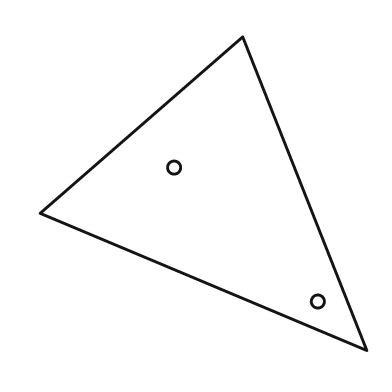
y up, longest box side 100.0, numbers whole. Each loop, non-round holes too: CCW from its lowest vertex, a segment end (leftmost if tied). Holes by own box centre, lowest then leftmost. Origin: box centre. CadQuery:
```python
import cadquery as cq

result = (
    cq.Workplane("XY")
    .moveTo(50.0, -48.0)
    .lineTo(12.0, 48.0)
    .lineTo(-50.0, -6.0)
    .close()
    .moveTo(35.0, -33.0)
    .circle(2.0)
    .moveTo(-9.0, 8.0)
    .circle(2.0)
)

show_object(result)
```